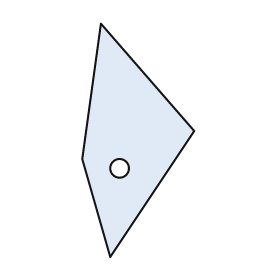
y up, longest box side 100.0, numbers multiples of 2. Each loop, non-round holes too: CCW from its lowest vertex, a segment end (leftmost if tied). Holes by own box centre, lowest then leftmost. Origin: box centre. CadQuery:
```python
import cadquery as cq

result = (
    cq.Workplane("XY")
    .moveTo(-12.0, -50.0)
    .lineTo(24.0, 4.0)
    .lineTo(-16.0, 50.0)
    .lineTo(-24.0, -8.0)
    .close()
    .moveTo(-8.0, -12.0)
    .circle(4.0)
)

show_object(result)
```